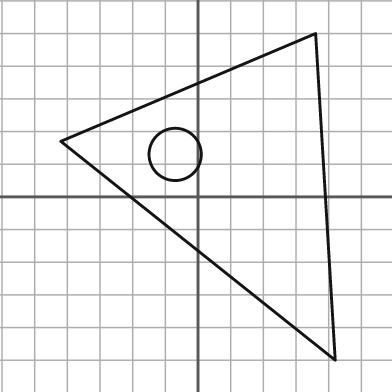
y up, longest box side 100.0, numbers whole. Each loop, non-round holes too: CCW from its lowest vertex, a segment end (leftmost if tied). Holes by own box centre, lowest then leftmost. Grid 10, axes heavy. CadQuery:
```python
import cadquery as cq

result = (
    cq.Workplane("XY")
    .moveTo(42.0, -50.0)
    .lineTo(36.0, 50.0)
    .lineTo(-42.0, 17.0)
    .close()
    .moveTo(-7.0, 13.0)
    .circle(8.0)
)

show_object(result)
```